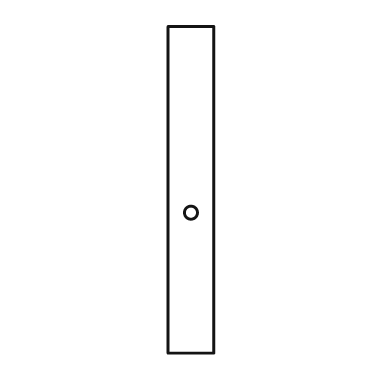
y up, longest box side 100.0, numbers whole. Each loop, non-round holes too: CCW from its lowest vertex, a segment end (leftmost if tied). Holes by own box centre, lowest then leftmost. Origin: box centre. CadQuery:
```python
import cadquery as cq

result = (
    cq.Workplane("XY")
    .moveTo(-7.0, -50.0)
    .lineTo(7.0, -50.0)
    .lineTo(7.0, 50.0)
    .lineTo(-7.0, 50.0)
    .close()
    .moveTo(0.0, -7.0)
    .circle(2.0)
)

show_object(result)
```